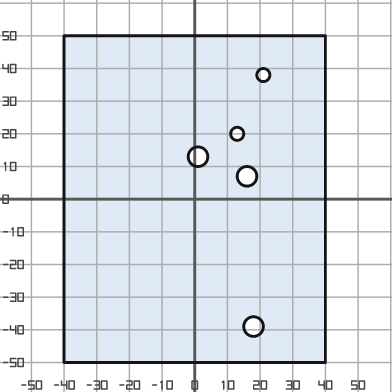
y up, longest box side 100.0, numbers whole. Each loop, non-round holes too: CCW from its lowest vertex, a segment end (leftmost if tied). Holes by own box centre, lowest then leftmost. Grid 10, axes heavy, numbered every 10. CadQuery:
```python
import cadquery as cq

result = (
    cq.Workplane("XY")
    .moveTo(-40.0, -50.0)
    .lineTo(40.0, -50.0)
    .lineTo(40.0, 50.0)
    .lineTo(-40.0, 50.0)
    .close()
    .moveTo(18.0, -39.0)
    .circle(3.0)
    .moveTo(16.0, 7.0)
    .circle(3.0)
    .moveTo(1.0, 13.0)
    .circle(3.0)
    .moveTo(13.0, 20.0)
    .circle(2.0)
    .moveTo(21.0, 38.0)
    .circle(2.0)
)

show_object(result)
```